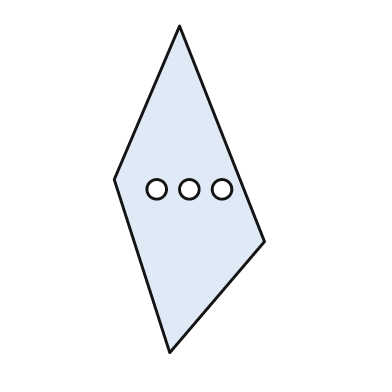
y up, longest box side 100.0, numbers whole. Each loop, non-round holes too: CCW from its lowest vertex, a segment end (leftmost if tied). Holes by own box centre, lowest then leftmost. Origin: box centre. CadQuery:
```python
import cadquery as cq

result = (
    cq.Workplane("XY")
    .moveTo(-6.0, -50.0)
    .lineTo(23.0, -16.0)
    .lineTo(-3.0, 50.0)
    .lineTo(-23.0, 3.0)
    .close()
    .moveTo(-10.0, 0.0)
    .circle(3.0)
    .moveTo(0.0, 0.0)
    .circle(3.0)
    .moveTo(10.0, 0.0)
    .circle(3.0)
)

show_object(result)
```